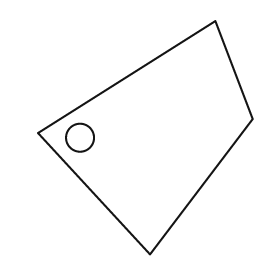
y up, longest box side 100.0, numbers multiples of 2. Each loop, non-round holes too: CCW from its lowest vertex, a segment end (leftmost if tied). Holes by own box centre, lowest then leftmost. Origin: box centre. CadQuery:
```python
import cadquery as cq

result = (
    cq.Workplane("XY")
    .moveTo(2.0, -50.0)
    .lineTo(46.0, 8.0)
    .lineTo(30.0, 50.0)
    .lineTo(-46.0, 2.0)
    .close()
    .moveTo(-28.0, 0.0)
    .circle(6.0)
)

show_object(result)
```